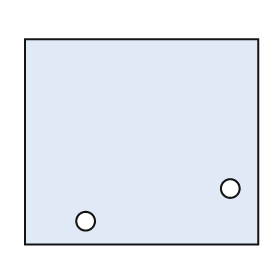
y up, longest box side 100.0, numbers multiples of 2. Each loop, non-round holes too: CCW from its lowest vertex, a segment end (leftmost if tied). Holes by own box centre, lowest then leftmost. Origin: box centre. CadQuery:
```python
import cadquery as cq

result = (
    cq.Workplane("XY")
    .moveTo(-50.0, -44.0)
    .lineTo(50.0, -44.0)
    .lineTo(50.0, 44.0)
    .lineTo(-50.0, 44.0)
    .close()
    .moveTo(-24.0, -34.0)
    .circle(4.0)
    .moveTo(38.0, -20.0)
    .circle(4.0)
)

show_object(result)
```